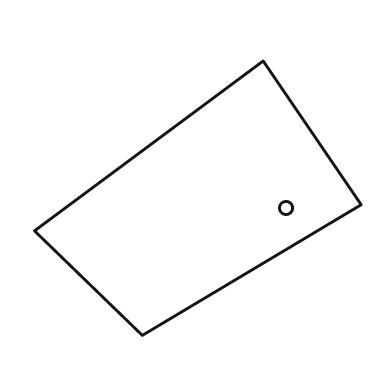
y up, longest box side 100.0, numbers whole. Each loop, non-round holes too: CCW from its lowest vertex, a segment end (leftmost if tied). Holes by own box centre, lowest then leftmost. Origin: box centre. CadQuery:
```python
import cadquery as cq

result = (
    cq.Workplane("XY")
    .moveTo(-17.0, -42.0)
    .lineTo(50.0, -2.0)
    .lineTo(20.0, 42.0)
    .lineTo(-50.0, -10.0)
    .close()
    .moveTo(27.0, -3.0)
    .circle(2.0)
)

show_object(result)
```